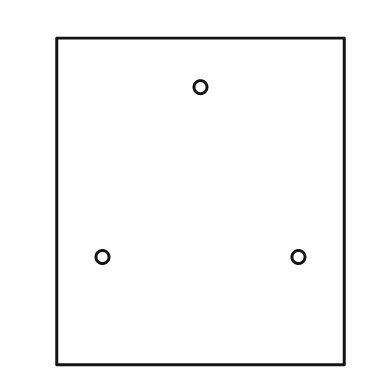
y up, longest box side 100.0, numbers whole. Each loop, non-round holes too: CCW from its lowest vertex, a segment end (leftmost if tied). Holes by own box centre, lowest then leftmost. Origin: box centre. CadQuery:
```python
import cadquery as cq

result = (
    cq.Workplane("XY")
    .moveTo(-44.0, -50.0)
    .lineTo(44.0, -50.0)
    .lineTo(44.0, 50.0)
    .lineTo(-44.0, 50.0)
    .close()
    .moveTo(-30.0, -17.0)
    .circle(2.0)
    .moveTo(30.0, -17.0)
    .circle(2.0)
    .moveTo(0.0, 35.0)
    .circle(2.0)
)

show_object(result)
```